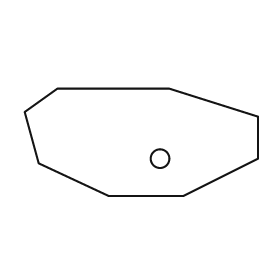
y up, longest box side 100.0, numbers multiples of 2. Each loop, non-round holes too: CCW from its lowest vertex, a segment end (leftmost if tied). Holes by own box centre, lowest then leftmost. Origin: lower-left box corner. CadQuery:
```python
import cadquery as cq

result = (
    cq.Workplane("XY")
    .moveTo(36.0, 0.0)
    .lineTo(68.0, 0.0)
    .lineTo(100.0, 16.0)
    .lineTo(100.0, 34.0)
    .lineTo(62.0, 46.0)
    .lineTo(14.0, 46.0)
    .lineTo(0.0, 36.0)
    .lineTo(6.0, 14.0)
    .close()
    .moveTo(58.0, 16.0)
    .circle(4.0)
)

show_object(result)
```